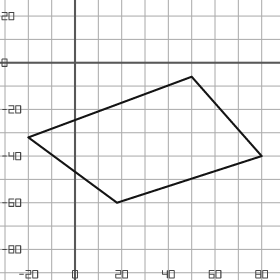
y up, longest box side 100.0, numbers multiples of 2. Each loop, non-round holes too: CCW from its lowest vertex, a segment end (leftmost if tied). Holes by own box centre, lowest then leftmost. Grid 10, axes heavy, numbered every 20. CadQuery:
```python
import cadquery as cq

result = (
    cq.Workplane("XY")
    .moveTo(18.0, -60.0)
    .lineTo(80.0, -40.0)
    .lineTo(50.0, -6.0)
    .lineTo(-20.0, -32.0)
    .close()
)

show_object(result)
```